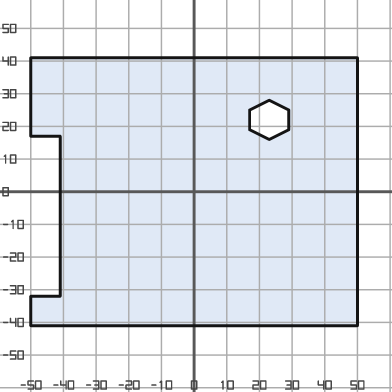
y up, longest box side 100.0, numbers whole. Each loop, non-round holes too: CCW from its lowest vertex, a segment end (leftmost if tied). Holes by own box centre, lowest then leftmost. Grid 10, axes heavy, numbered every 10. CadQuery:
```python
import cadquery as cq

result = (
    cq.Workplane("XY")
    .moveTo(-50.0, -41.0)
    .lineTo(50.0, -41.0)
    .lineTo(50.0, 41.0)
    .lineTo(-50.0, 41.0)
    .lineTo(-50.0, 17.0)
    .lineTo(-41.0, 17.0)
    .lineTo(-41.0, -32.0)
    .lineTo(-50.0, -32.0)
    .close()
    .moveTo(23.0, 16.0)
    .lineTo(29.0, 19.0)
    .lineTo(29.0, 25.0)
    .lineTo(23.0, 28.0)
    .lineTo(17.0, 25.0)
    .lineTo(17.0, 19.0)
    .close()
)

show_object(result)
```